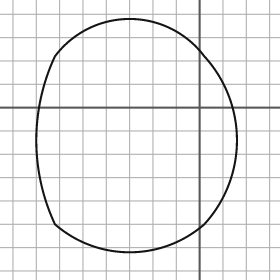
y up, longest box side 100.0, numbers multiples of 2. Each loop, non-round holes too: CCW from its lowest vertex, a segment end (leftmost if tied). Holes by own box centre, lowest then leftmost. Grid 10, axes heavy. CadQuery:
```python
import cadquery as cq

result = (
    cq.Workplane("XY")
    .moveTo(-62.0, -50.0)
    .threePointArc((-30.0, -62.0), (2.0, -50.0))
    .threePointArc((16.0, -14.0), (2.0, 22.0))
    .threePointArc((-30.0, 38.0), (-62.0, 22.0))
    .threePointArc((-70.0, -14.0), (-62.0, -50.0))
    .close()
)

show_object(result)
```